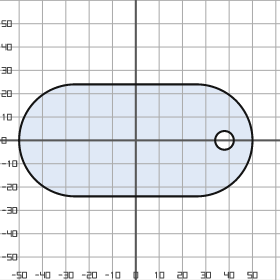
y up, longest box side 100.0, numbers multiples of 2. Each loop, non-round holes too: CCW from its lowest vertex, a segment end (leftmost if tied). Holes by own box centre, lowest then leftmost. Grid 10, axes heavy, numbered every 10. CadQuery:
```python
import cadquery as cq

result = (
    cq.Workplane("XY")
    .moveTo(-26.0, -24.0)
    .lineTo(26.0, -24.0)
    .threePointArc((50.0, 0.0), (26.0, 24.0))
    .lineTo(-26.0, 24.0)
    .threePointArc((-50.0, 0.0), (-26.0, -24.0))
    .close()
    .moveTo(38.0, 0.0)
    .circle(4.0)
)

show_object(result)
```